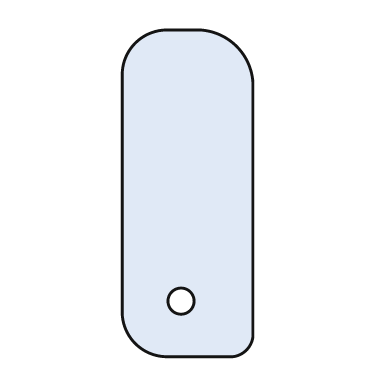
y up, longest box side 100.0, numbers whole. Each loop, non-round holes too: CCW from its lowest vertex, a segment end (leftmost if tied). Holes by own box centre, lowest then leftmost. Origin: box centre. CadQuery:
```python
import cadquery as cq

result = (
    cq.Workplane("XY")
    .moveTo(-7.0, -50.0)
    .lineTo(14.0, -50.0)
    .threePointArc((18.0, -48.0), (20.0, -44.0))
    .lineTo(20.0, 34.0)
    .threePointArc((15.0, 45.0), (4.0, 50.0))
    .lineTo(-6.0, 50.0)
    .threePointArc((-16.0, 46.0), (-20.0, 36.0))
    .lineTo(-20.0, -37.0)
    .threePointArc((-16.0, -46.0), (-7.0, -50.0))
    .close()
    .moveTo(-2.0, -33.0)
    .circle(4.0)
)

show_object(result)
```